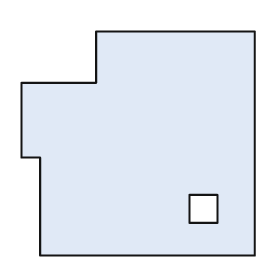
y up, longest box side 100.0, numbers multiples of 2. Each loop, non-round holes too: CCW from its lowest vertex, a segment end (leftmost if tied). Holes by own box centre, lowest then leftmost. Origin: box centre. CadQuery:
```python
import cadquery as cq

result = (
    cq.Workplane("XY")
    .moveTo(-42.0, -48.0)
    .lineTo(50.0, -48.0)
    .lineTo(50.0, 48.0)
    .lineTo(-18.0, 48.0)
    .lineTo(-18.0, 26.0)
    .lineTo(-50.0, 26.0)
    .lineTo(-50.0, -6.0)
    .lineTo(-42.0, -6.0)
    .close()
    .moveTo(22.0, -34.0)
    .lineTo(34.0, -34.0)
    .lineTo(34.0, -22.0)
    .lineTo(22.0, -22.0)
    .close()
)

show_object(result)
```